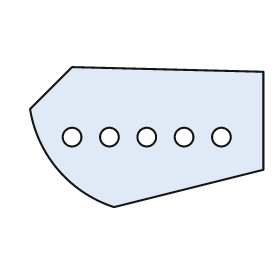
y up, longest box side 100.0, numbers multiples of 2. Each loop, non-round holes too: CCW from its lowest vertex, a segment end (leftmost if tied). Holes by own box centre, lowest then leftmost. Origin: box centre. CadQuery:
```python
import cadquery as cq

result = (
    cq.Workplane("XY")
    .moveTo(-14.0, -30.0)
    .lineTo(50.0, -14.0)
    .lineTo(50.0, 28.0)
    .lineTo(-32.0, 30.0)
    .lineTo(-50.0, 12.0)
    .threePointArc((-38.0, -14.0), (-14.0, -30.0))
    .close()
    .moveTo(-32.0, 0.0)
    .circle(4.0)
    .moveTo(-16.0, 0.0)
    .circle(4.0)
    .moveTo(0.0, 0.0)
    .circle(4.0)
    .moveTo(16.0, 0.0)
    .circle(4.0)
    .moveTo(32.0, 0.0)
    .circle(4.0)
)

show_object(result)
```